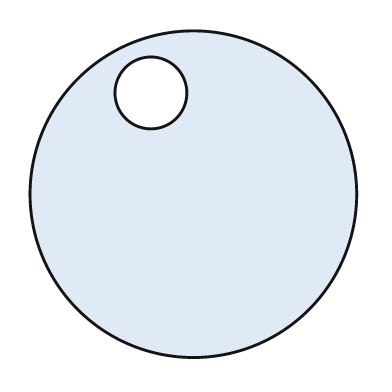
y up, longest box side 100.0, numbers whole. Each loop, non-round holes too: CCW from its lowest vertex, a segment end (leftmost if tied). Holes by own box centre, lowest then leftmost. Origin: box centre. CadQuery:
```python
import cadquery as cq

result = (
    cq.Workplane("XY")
    .moveTo(0.0, 0.0)
    .circle(50.0)
    .moveTo(-13.0, 31.0)
    .circle(11.0)
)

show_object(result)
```